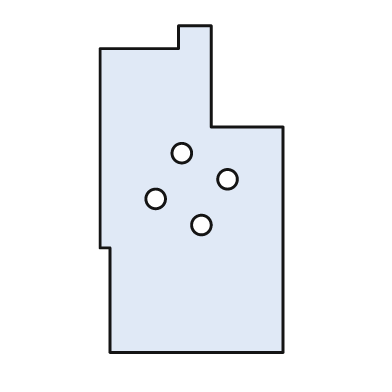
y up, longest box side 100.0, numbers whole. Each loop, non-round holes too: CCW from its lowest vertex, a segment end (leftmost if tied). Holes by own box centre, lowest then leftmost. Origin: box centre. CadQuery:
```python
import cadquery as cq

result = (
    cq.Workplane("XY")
    .moveTo(-25.0, -50.0)
    .lineTo(28.0, -50.0)
    .lineTo(28.0, 19.0)
    .lineTo(6.0, 19.0)
    .lineTo(6.0, 50.0)
    .lineTo(-4.0, 50.0)
    .lineTo(-4.0, 43.0)
    .lineTo(-28.0, 43.0)
    .lineTo(-28.0, -18.0)
    .lineTo(-25.0, -18.0)
    .close()
    .moveTo(3.0, -11.0)
    .circle(3.0)
    .moveTo(-11.0, -3.0)
    .circle(3.0)
    .moveTo(11.0, 3.0)
    .circle(3.0)
    .moveTo(-3.0, 11.0)
    .circle(3.0)
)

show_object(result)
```